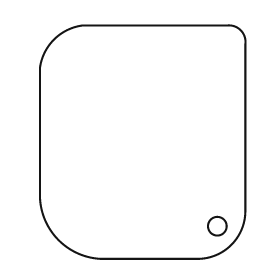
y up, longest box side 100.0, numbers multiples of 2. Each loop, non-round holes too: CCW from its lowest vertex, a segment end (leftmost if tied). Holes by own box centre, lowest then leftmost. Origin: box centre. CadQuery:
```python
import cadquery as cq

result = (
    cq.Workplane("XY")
    .moveTo(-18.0, -50.0)
    .lineTo(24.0, -50.0)
    .threePointArc((38.0, -44.0), (44.0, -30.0))
    .lineTo(44.0, 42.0)
    .threePointArc((42.0, 48.0), (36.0, 50.0))
    .lineTo(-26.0, 50.0)
    .threePointArc((-38.0, 44.0), (-44.0, 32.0))
    .lineTo(-44.0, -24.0)
    .threePointArc((-36.0, -42.0), (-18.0, -50.0))
    .close()
    .moveTo(32.0, -36.0)
    .circle(4.0)
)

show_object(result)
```